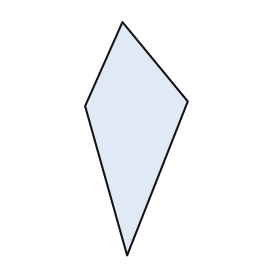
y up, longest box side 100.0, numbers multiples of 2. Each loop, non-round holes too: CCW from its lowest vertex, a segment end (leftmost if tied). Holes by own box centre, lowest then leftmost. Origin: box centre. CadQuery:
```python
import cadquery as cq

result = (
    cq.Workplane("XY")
    .moveTo(-4.0, -50.0)
    .lineTo(22.0, 16.0)
    .lineTo(-6.0, 50.0)
    .lineTo(-22.0, 14.0)
    .close()
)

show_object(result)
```